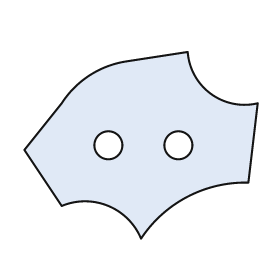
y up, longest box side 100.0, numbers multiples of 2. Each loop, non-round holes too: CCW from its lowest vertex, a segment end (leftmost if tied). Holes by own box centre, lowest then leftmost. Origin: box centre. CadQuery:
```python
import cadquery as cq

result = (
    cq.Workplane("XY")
    .moveTo(0.0, -40.0)
    .threePointArc((20.0, -22.0), (46.0, -16.0))
    .lineTo(50.0, 18.0)
    .threePointArc((30.0, 22.0), (20.0, 40.0))
    .lineTo(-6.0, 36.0)
    .threePointArc((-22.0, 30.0), (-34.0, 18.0))
    .lineTo(-50.0, -2.0)
    .lineTo(-34.0, -26.0)
    .threePointArc((-14.0, -26.0), (0.0, -40.0))
    .close()
    .moveTo(-14.0, 0.0)
    .circle(6.0)
    .moveTo(16.0, 0.0)
    .circle(6.0)
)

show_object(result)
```